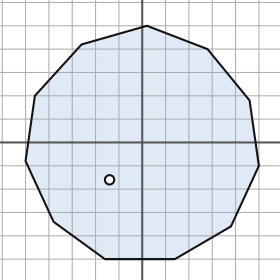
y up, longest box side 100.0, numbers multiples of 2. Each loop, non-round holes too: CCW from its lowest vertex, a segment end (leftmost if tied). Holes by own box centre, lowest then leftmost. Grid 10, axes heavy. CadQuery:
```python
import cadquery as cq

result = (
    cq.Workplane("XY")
    .moveTo(-16.0, -50.0)
    .lineTo(14.0, -50.0)
    .lineTo(38.0, -36.0)
    .lineTo(50.0, -10.0)
    .lineTo(46.0, 18.0)
    .lineTo(28.0, 40.0)
    .lineTo(2.0, 50.0)
    .lineTo(-26.0, 42.0)
    .lineTo(-46.0, 20.0)
    .lineTo(-50.0, -8.0)
    .lineTo(-38.0, -34.0)
    .close()
    .moveTo(-14.0, -16.0)
    .circle(2.0)
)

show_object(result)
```